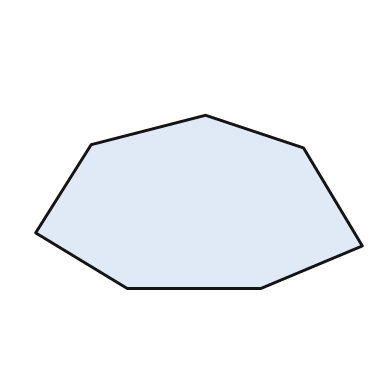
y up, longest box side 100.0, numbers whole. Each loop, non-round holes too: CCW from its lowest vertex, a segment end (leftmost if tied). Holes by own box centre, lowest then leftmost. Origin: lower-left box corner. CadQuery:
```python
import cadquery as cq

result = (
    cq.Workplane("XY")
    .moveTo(28.0, 0.0)
    .lineTo(69.0, 0.0)
    .lineTo(100.0, 13.0)
    .lineTo(82.0, 43.0)
    .lineTo(52.0, 53.0)
    .lineTo(17.0, 44.0)
    .lineTo(0.0, 17.0)
    .close()
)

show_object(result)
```